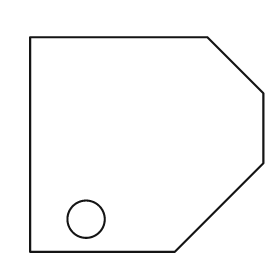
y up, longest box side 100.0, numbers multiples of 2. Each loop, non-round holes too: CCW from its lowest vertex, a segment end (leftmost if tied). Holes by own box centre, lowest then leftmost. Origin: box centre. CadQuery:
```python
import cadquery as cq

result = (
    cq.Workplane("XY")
    .moveTo(-50.0, -46.0)
    .lineTo(12.0, -46.0)
    .lineTo(50.0, -8.0)
    .lineTo(50.0, 22.0)
    .lineTo(26.0, 46.0)
    .lineTo(-50.0, 46.0)
    .close()
    .moveTo(-26.0, -32.0)
    .circle(8.0)
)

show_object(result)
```